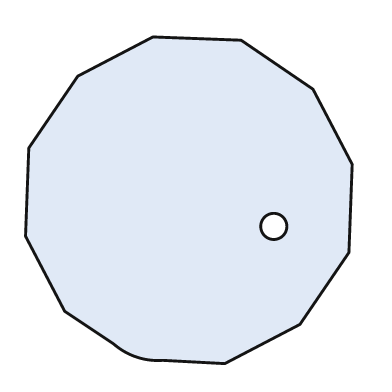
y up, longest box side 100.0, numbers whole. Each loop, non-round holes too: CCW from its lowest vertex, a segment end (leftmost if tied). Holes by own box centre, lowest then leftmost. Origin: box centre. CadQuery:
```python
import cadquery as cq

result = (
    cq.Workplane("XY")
    .moveTo(11.0, -50.0)
    .lineTo(34.0, -38.0)
    .lineTo(49.0, -16.0)
    .lineTo(50.0, 11.0)
    .lineTo(38.0, 34.0)
    .lineTo(16.0, 49.0)
    .lineTo(-11.0, 50.0)
    .lineTo(-34.0, 38.0)
    .lineTo(-49.0, 16.0)
    .lineTo(-50.0, -11.0)
    .lineTo(-38.0, -34.0)
    .lineTo(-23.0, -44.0)
    .threePointArc((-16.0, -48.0), (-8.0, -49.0))
    .close()
    .moveTo(26.0, -8.0)
    .circle(4.0)
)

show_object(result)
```